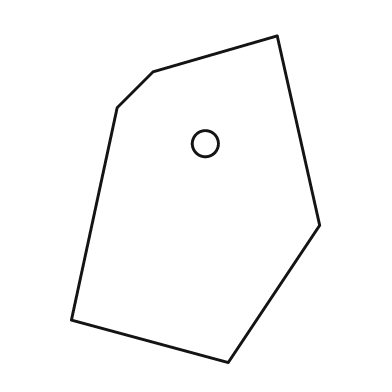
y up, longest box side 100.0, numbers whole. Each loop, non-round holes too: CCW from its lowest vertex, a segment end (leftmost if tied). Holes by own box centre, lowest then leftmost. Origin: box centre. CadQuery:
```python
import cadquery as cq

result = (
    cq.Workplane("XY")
    .moveTo(10.0, -50.0)
    .lineTo(38.0, -8.0)
    .lineTo(25.0, 50.0)
    .lineTo(-13.0, 39.0)
    .lineTo(-24.0, 28.0)
    .lineTo(-38.0, -37.0)
    .close()
    .moveTo(3.0, 17.0)
    .circle(4.0)
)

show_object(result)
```